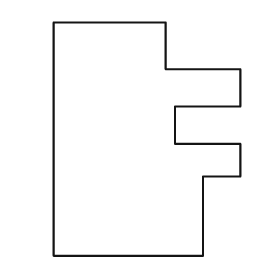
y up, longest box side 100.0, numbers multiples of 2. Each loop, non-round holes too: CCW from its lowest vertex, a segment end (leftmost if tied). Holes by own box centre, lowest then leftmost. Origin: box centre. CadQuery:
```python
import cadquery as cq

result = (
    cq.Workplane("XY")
    .moveTo(-40.0, -50.0)
    .lineTo(24.0, -50.0)
    .lineTo(24.0, -16.0)
    .lineTo(40.0, -16.0)
    .lineTo(40.0, -2.0)
    .lineTo(12.0, -2.0)
    .lineTo(12.0, 14.0)
    .lineTo(40.0, 14.0)
    .lineTo(40.0, 30.0)
    .lineTo(8.0, 30.0)
    .lineTo(8.0, 50.0)
    .lineTo(-40.0, 50.0)
    .close()
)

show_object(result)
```